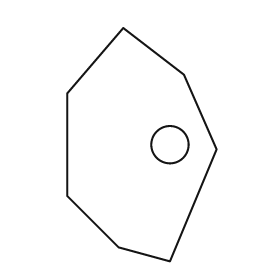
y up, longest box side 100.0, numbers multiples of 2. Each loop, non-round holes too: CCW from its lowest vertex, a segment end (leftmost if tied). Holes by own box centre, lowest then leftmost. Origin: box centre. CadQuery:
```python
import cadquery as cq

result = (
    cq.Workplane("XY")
    .moveTo(12.0, -50.0)
    .lineTo(32.0, -2.0)
    .lineTo(18.0, 30.0)
    .lineTo(-8.0, 50.0)
    .lineTo(-32.0, 22.0)
    .lineTo(-32.0, -22.0)
    .lineTo(-10.0, -44.0)
    .close()
    .moveTo(12.0, 0.0)
    .circle(8.0)
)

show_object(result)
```